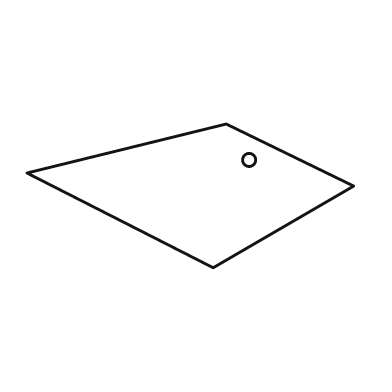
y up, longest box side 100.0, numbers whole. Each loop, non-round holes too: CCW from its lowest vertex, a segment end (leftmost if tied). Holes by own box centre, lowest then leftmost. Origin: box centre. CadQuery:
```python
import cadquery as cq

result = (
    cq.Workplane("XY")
    .moveTo(7.0, -22.0)
    .lineTo(50.0, 3.0)
    .lineTo(11.0, 22.0)
    .lineTo(-50.0, 7.0)
    .close()
    .moveTo(18.0, 11.0)
    .circle(2.0)
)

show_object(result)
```